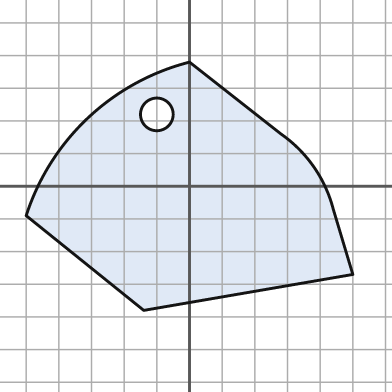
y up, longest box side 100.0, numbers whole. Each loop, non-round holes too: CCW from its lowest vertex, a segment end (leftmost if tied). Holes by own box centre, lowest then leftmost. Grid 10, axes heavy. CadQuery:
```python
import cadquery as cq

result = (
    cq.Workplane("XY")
    .moveTo(-14.0, -38.0)
    .lineTo(50.0, -27.0)
    .lineTo(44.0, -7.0)
    .threePointArc((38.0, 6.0), (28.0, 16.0))
    .lineTo(0.0, 38.0)
    .threePointArc((-31.0, 21.0), (-50.0, -9.0))
    .close()
    .moveTo(-10.0, 22.0)
    .circle(5.0)
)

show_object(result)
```